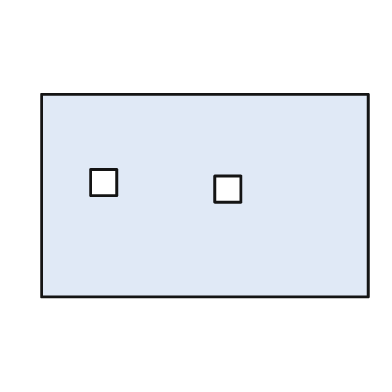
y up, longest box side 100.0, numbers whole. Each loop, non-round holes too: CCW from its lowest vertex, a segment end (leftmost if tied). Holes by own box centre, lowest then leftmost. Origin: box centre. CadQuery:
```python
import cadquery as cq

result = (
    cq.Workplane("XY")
    .moveTo(-50.0, -31.0)
    .lineTo(50.0, -31.0)
    .lineTo(50.0, 31.0)
    .lineTo(-50.0, 31.0)
    .close()
    .moveTo(3.0, -2.0)
    .lineTo(11.0, -2.0)
    .lineTo(11.0, 6.0)
    .lineTo(3.0, 6.0)
    .close()
    .moveTo(-35.0, 0.0)
    .lineTo(-27.0, 0.0)
    .lineTo(-27.0, 8.0)
    .lineTo(-35.0, 8.0)
    .close()
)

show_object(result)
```